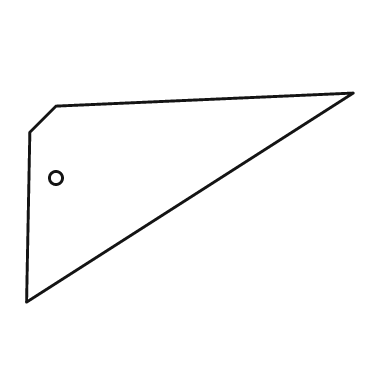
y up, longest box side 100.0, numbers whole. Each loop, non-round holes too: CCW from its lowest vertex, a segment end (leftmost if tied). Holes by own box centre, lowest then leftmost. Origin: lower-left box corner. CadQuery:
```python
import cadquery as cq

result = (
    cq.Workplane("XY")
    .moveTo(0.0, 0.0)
    .lineTo(100.0, 64.0)
    .lineTo(9.0, 60.0)
    .lineTo(1.0, 52.0)
    .close()
    .moveTo(9.0, 38.0)
    .circle(2.0)
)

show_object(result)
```